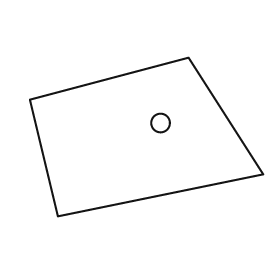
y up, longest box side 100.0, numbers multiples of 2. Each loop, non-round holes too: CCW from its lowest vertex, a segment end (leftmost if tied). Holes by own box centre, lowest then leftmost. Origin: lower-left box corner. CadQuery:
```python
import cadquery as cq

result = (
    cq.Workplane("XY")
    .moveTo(12.0, 0.0)
    .lineTo(100.0, 18.0)
    .lineTo(68.0, 68.0)
    .lineTo(0.0, 50.0)
    .close()
    .moveTo(56.0, 40.0)
    .circle(4.0)
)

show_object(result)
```